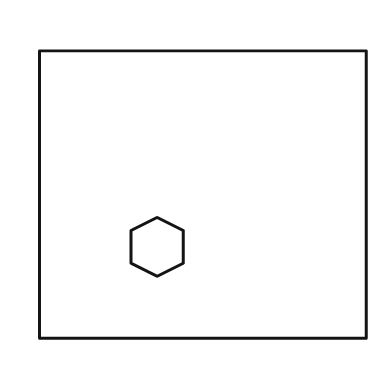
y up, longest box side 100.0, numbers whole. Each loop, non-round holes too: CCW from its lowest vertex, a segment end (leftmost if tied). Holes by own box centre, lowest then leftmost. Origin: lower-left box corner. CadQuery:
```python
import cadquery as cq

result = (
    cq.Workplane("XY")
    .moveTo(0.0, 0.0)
    .lineTo(100.0, 0.0)
    .lineTo(100.0, 88.0)
    .lineTo(0.0, 88.0)
    .close()
    .moveTo(36.0, 19.0)
    .lineTo(44.0, 23.0)
    .lineTo(44.0, 33.0)
    .lineTo(36.0, 37.0)
    .lineTo(28.0, 33.0)
    .lineTo(28.0, 23.0)
    .close()
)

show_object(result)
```